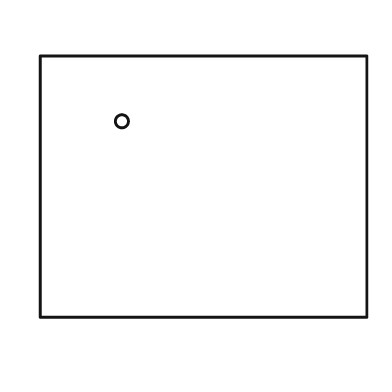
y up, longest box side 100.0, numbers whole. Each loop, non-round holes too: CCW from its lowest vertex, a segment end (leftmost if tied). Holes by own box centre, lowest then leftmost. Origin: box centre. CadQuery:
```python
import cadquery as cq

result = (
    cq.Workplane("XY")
    .moveTo(-50.0, -40.0)
    .lineTo(50.0, -40.0)
    .lineTo(50.0, 40.0)
    .lineTo(-50.0, 40.0)
    .close()
    .moveTo(-25.0, 20.0)
    .circle(2.0)
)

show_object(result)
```